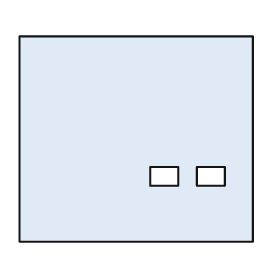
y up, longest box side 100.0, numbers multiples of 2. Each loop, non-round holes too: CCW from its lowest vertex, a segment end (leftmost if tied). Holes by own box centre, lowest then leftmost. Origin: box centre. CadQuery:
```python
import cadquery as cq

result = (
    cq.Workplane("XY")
    .moveTo(-50.0, -44.0)
    .lineTo(50.0, -44.0)
    .lineTo(50.0, 44.0)
    .lineTo(-50.0, 44.0)
    .close()
    .moveTo(6.0, -20.0)
    .lineTo(18.0, -20.0)
    .lineTo(18.0, -12.0)
    .lineTo(6.0, -12.0)
    .close()
    .moveTo(26.0, -20.0)
    .lineTo(38.0, -20.0)
    .lineTo(38.0, -12.0)
    .lineTo(26.0, -12.0)
    .close()
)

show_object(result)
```